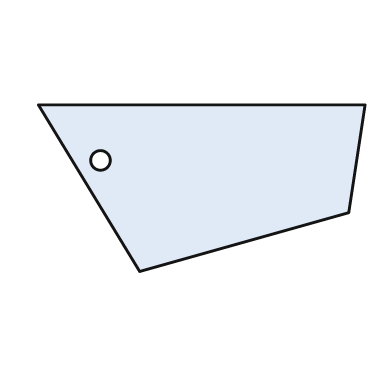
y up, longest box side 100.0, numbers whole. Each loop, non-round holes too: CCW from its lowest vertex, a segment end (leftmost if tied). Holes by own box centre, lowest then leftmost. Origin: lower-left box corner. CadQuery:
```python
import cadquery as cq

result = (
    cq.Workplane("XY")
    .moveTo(31.0, 0.0)
    .lineTo(95.0, 18.0)
    .lineTo(100.0, 51.0)
    .lineTo(0.0, 51.0)
    .close()
    .moveTo(19.0, 34.0)
    .circle(3.0)
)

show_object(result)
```